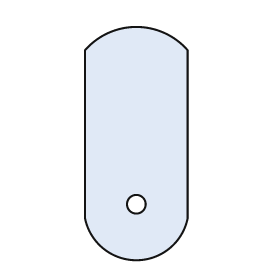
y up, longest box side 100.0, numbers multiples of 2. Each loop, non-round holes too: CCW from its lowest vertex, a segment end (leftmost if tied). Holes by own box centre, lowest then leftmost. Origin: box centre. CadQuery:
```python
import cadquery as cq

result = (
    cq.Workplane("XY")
    .moveTo(-22.0, -32.0)
    .threePointArc((0.0, -50.0), (22.0, -32.0))
    .lineTo(22.0, 40.0)
    .threePointArc((0.0, 50.0), (-22.0, 40.0))
    .close()
    .moveTo(0.0, -26.0)
    .circle(4.0)
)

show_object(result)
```